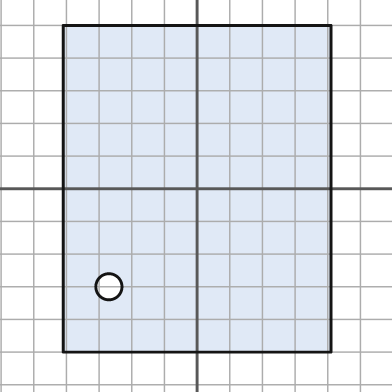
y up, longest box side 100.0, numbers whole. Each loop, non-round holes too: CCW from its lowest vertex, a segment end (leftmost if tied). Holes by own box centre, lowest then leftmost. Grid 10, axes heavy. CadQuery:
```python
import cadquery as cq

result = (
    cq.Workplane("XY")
    .moveTo(-41.0, -50.0)
    .lineTo(41.0, -50.0)
    .lineTo(41.0, 50.0)
    .lineTo(-41.0, 50.0)
    .close()
    .moveTo(-27.0, -30.0)
    .circle(4.0)
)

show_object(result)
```